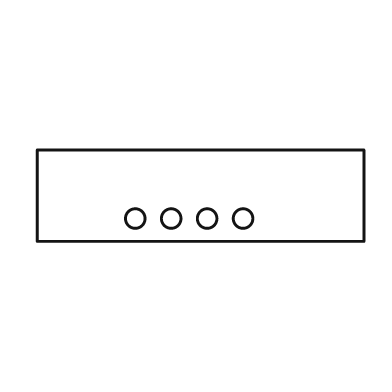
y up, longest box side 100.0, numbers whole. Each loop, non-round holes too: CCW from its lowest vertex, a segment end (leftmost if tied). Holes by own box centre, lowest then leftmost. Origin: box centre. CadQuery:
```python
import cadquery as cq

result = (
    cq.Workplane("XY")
    .moveTo(-50.0, -14.0)
    .lineTo(50.0, -14.0)
    .lineTo(50.0, 14.0)
    .lineTo(-50.0, 14.0)
    .close()
    .moveTo(-20.0, -7.0)
    .circle(3.0)
    .moveTo(-9.0, -7.0)
    .circle(3.0)
    .moveTo(2.0, -7.0)
    .circle(3.0)
    .moveTo(13.0, -7.0)
    .circle(3.0)
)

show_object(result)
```